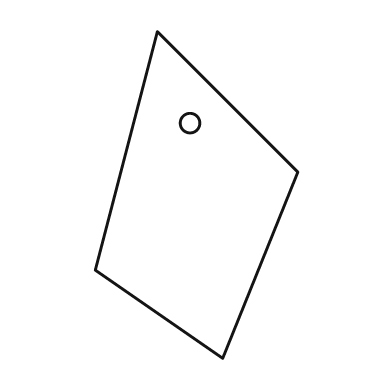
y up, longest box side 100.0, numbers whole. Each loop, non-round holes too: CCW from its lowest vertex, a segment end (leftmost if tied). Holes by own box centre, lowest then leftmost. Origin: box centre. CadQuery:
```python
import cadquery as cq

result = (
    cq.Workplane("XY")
    .moveTo(8.0, -50.0)
    .lineTo(31.0, 7.0)
    .lineTo(-12.0, 50.0)
    .lineTo(-31.0, -23.0)
    .close()
    .moveTo(-2.0, 22.0)
    .circle(3.0)
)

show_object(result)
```